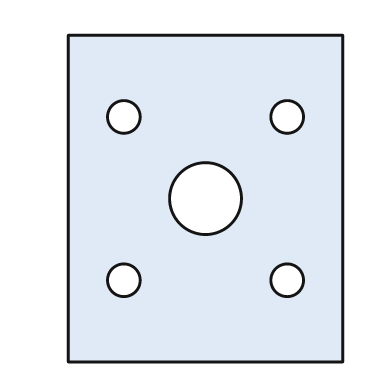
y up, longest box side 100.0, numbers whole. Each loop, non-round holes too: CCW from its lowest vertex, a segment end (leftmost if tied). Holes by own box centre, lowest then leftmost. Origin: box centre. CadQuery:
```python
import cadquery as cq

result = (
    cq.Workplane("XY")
    .moveTo(-42.0, -50.0)
    .lineTo(42.0, -50.0)
    .lineTo(42.0, 50.0)
    .lineTo(-42.0, 50.0)
    .close()
    .moveTo(-25.0, -25.0)
    .circle(5.0)
    .moveTo(25.0, -25.0)
    .circle(5.0)
    .moveTo(0.0, 0.0)
    .circle(11.0)
    .moveTo(-25.0, 25.0)
    .circle(5.0)
    .moveTo(25.0, 25.0)
    .circle(5.0)
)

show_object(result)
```